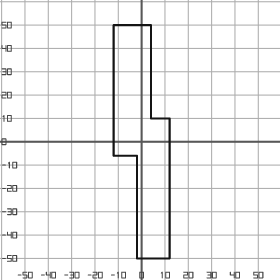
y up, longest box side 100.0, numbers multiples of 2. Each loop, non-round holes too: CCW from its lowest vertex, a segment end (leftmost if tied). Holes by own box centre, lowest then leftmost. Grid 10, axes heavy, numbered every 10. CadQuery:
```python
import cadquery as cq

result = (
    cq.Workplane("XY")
    .moveTo(-2.0, -50.0)
    .lineTo(12.0, -50.0)
    .lineTo(12.0, 10.0)
    .lineTo(4.0, 10.0)
    .lineTo(4.0, 50.0)
    .lineTo(-12.0, 50.0)
    .lineTo(-12.0, -6.0)
    .lineTo(-2.0, -6.0)
    .close()
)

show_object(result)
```